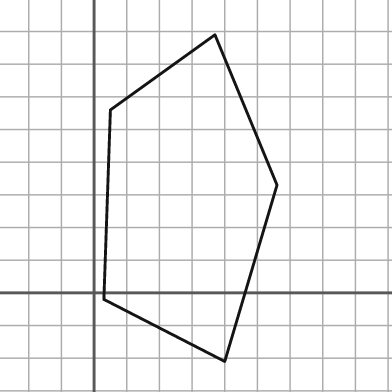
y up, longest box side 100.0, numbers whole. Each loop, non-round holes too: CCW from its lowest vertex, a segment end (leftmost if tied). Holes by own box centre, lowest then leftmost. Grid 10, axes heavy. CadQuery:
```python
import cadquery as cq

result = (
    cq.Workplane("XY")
    .moveTo(40.0, -21.0)
    .lineTo(56.0, 33.0)
    .lineTo(37.0, 79.0)
    .lineTo(5.0, 56.0)
    .lineTo(3.0, -2.0)
    .close()
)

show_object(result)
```